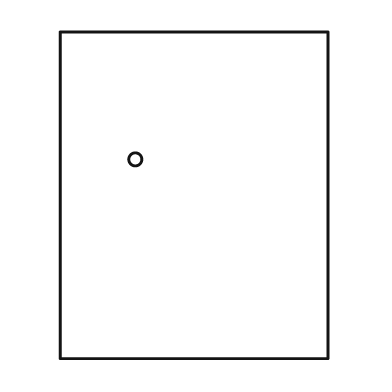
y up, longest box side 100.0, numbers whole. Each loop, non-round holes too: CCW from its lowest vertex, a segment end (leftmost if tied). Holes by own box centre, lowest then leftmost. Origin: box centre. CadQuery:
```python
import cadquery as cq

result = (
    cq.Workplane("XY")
    .moveTo(-41.0, -50.0)
    .lineTo(41.0, -50.0)
    .lineTo(41.0, 50.0)
    .lineTo(-41.0, 50.0)
    .close()
    .moveTo(-18.0, 11.0)
    .circle(2.0)
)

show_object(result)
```